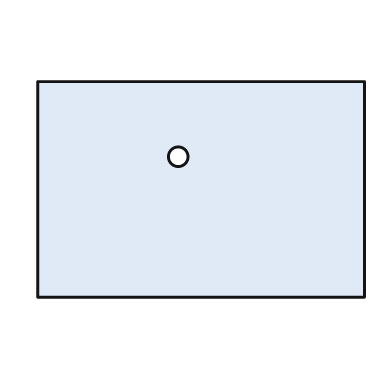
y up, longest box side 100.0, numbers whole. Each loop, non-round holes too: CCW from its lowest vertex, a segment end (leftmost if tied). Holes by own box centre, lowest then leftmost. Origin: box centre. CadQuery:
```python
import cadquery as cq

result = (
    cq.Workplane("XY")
    .moveTo(-50.0, -33.0)
    .lineTo(50.0, -33.0)
    .lineTo(50.0, 33.0)
    .lineTo(-50.0, 33.0)
    .close()
    .moveTo(-7.0, 10.0)
    .circle(3.0)
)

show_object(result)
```